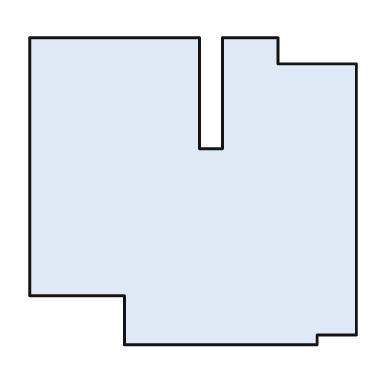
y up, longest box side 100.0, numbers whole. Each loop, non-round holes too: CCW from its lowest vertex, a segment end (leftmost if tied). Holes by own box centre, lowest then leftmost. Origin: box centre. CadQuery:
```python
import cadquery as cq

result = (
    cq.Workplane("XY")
    .moveTo(-21.0, -47.0)
    .lineTo(38.0, -47.0)
    .lineTo(38.0, -44.0)
    .lineTo(50.0, -44.0)
    .lineTo(50.0, 39.0)
    .lineTo(26.0, 39.0)
    .lineTo(26.0, 47.0)
    .lineTo(9.0, 47.0)
    .lineTo(9.0, 13.0)
    .lineTo(2.0, 13.0)
    .lineTo(2.0, 47.0)
    .lineTo(-50.0, 47.0)
    .lineTo(-50.0, -32.0)
    .lineTo(-21.0, -32.0)
    .close()
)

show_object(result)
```